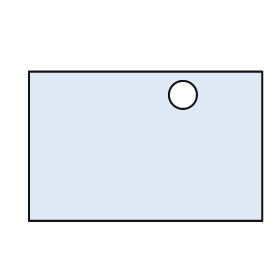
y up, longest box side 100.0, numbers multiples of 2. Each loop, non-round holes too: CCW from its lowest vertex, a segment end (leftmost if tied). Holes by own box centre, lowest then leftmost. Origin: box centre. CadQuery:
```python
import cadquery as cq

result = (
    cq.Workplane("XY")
    .moveTo(-50.0, -32.0)
    .lineTo(50.0, -32.0)
    .lineTo(50.0, 32.0)
    .lineTo(-50.0, 32.0)
    .close()
    .moveTo(16.0, 22.0)
    .circle(6.0)
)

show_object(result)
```